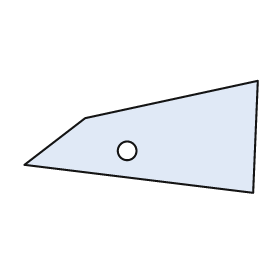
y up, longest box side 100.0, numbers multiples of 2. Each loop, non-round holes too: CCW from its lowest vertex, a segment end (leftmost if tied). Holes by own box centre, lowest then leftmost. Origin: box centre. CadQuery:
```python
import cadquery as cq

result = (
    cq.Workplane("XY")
    .moveTo(48.0, -24.0)
    .lineTo(50.0, 24.0)
    .lineTo(-24.0, 8.0)
    .lineTo(-50.0, -12.0)
    .close()
    .moveTo(-6.0, -6.0)
    .circle(4.0)
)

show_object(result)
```